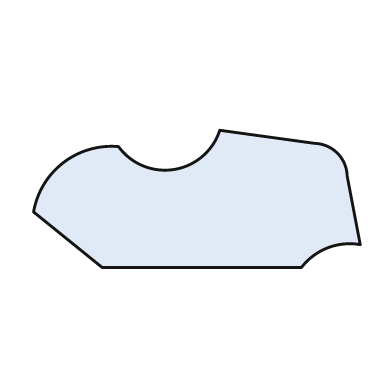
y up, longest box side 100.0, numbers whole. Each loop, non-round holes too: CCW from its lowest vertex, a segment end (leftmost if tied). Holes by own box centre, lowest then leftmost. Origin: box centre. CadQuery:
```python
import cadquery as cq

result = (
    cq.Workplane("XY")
    .moveTo(-29.0, -21.0)
    .lineTo(32.0, -21.0)
    .threePointArc((40.0, -15.0), (50.0, -14.0))
    .lineTo(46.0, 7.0)
    .threePointArc((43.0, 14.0), (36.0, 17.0))
    .lineTo(7.0, 21.0)
    .threePointArc((-7.0, 9.0), (-24.0, 16.0))
    .threePointArc((-41.0, 11.0), (-50.0, -4.0))
    .close()
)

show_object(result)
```